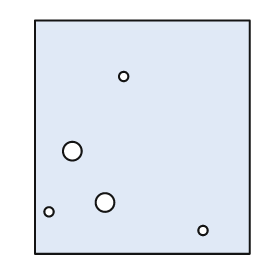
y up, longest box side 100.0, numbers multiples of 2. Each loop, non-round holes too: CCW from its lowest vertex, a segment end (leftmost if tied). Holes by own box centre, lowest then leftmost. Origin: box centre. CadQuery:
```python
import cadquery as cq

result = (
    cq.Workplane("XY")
    .moveTo(-46.0, -50.0)
    .lineTo(46.0, -50.0)
    .lineTo(46.0, 50.0)
    .lineTo(-46.0, 50.0)
    .close()
    .moveTo(26.0, -40.0)
    .circle(2.0)
    .moveTo(-40.0, -32.0)
    .circle(2.0)
    .moveTo(-16.0, -28.0)
    .circle(4.0)
    .moveTo(-30.0, -6.0)
    .circle(4.0)
    .moveTo(-8.0, 26.0)
    .circle(2.0)
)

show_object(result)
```